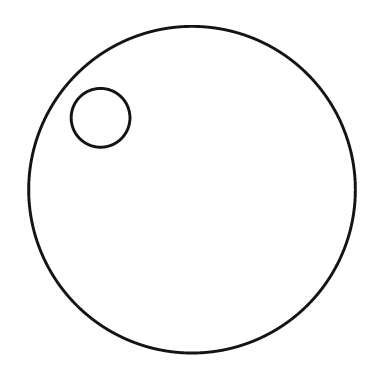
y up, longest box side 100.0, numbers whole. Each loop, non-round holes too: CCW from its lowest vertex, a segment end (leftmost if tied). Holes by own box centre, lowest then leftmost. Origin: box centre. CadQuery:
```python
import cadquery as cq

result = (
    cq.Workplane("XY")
    .moveTo(0.0, 0.0)
    .circle(50.0)
    .moveTo(-28.0, 22.0)
    .circle(9.0)
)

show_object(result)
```